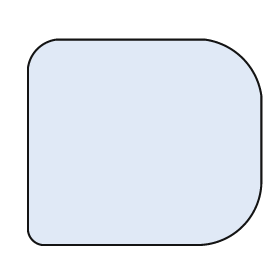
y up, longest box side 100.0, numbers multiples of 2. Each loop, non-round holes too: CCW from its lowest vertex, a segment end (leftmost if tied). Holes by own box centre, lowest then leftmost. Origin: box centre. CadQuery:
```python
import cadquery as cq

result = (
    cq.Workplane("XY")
    .moveTo(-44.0, -44.0)
    .lineTo(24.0, -44.0)
    .threePointArc((42.0, -36.0), (50.0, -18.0))
    .lineTo(50.0, 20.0)
    .threePointArc((42.0, 36.0), (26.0, 44.0))
    .lineTo(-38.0, 44.0)
    .threePointArc((-46.0, 40.0), (-50.0, 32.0))
    .lineTo(-50.0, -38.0)
    .threePointArc((-48.0, -42.0), (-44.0, -44.0))
    .close()
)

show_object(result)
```